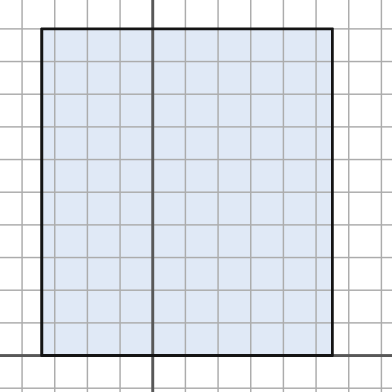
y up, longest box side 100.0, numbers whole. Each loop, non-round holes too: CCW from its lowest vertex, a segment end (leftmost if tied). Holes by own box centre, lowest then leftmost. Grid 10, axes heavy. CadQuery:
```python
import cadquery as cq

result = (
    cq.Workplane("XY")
    .moveTo(-34.0, 0.0)
    .lineTo(55.0, 0.0)
    .lineTo(55.0, 100.0)
    .lineTo(-34.0, 100.0)
    .close()
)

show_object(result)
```